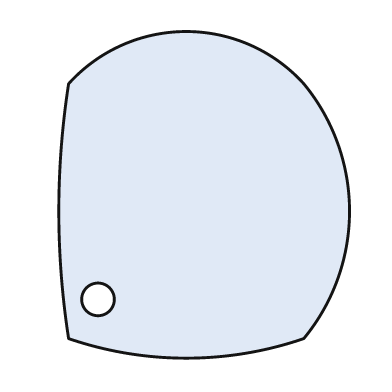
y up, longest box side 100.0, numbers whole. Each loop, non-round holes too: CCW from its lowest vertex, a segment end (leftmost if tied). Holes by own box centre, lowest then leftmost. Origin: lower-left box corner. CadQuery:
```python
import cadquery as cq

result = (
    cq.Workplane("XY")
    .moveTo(3.0, 6.0)
    .threePointArc((39.0, 0.0), (75.0, 6.0))
    .threePointArc((89.0, 45.0), (75.0, 84.0))
    .threePointArc((39.0, 100.0), (3.0, 84.0))
    .threePointArc((0.0, 45.0), (3.0, 6.0))
    .close()
    .moveTo(12.0, 18.0)
    .circle(5.0)
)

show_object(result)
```